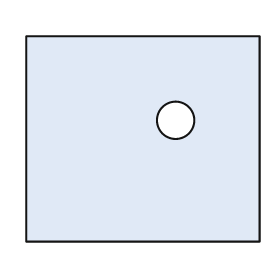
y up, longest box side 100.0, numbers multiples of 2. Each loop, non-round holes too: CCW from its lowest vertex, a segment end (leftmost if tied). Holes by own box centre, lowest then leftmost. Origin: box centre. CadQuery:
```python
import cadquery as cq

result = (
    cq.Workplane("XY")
    .moveTo(-50.0, -44.0)
    .lineTo(50.0, -44.0)
    .lineTo(50.0, 44.0)
    .lineTo(-50.0, 44.0)
    .close()
    .moveTo(14.0, 8.0)
    .circle(8.0)
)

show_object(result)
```